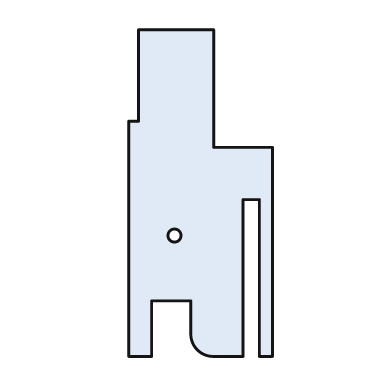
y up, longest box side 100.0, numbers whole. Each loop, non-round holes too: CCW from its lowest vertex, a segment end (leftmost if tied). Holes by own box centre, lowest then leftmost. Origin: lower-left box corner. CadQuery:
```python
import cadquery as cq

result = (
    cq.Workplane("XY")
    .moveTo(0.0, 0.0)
    .lineTo(7.0, 0.0)
    .lineTo(7.0, 17.0)
    .lineTo(19.0, 17.0)
    .lineTo(19.0, 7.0)
    .threePointArc((21.0, 2.0), (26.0, 0.0))
    .lineTo(35.0, 0.0)
    .lineTo(35.0, 48.0)
    .lineTo(40.0, 48.0)
    .lineTo(40.0, 0.0)
    .lineTo(44.0, 0.0)
    .lineTo(44.0, 64.0)
    .lineTo(26.0, 64.0)
    .lineTo(26.0, 100.0)
    .lineTo(3.0, 100.0)
    .lineTo(3.0, 72.0)
    .lineTo(0.0, 72.0)
    .close()
    .moveTo(14.0, 37.0)
    .circle(2.0)
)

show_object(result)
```